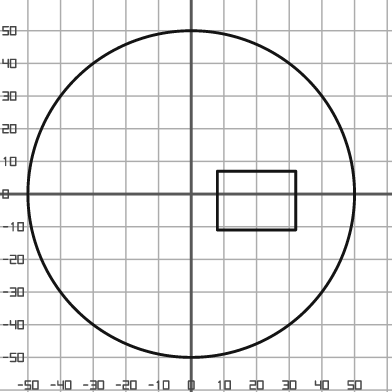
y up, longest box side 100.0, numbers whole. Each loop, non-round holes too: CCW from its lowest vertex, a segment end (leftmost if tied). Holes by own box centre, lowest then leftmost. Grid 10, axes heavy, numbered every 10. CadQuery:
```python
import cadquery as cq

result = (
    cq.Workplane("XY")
    .moveTo(0.0, 0.0)
    .circle(50.0)
    .moveTo(8.0, -11.0)
    .lineTo(32.0, -11.0)
    .lineTo(32.0, 7.0)
    .lineTo(8.0, 7.0)
    .close()
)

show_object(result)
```